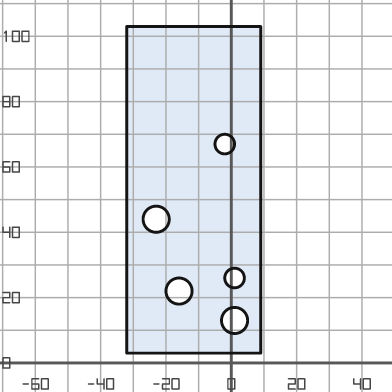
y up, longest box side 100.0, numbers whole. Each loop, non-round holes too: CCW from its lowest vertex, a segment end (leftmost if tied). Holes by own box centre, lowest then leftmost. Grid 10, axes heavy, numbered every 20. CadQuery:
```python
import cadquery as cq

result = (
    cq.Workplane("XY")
    .moveTo(-32.0, 3.0)
    .lineTo(9.0, 3.0)
    .lineTo(9.0, 103.0)
    .lineTo(-32.0, 103.0)
    .close()
    .moveTo(1.0, 13.0)
    .circle(4.0)
    .moveTo(-16.0, 22.0)
    .circle(4.0)
    .moveTo(1.0, 26.0)
    .circle(3.0)
    .moveTo(-23.0, 44.0)
    .circle(4.0)
    .moveTo(-2.0, 67.0)
    .circle(3.0)
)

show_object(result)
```